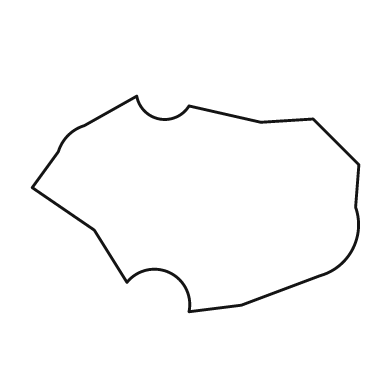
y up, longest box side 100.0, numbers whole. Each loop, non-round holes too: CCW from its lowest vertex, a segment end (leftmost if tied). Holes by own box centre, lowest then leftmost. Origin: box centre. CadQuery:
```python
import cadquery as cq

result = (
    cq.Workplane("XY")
    .moveTo(-2.0, -33.0)
    .lineTo(14.0, -31.0)
    .lineTo(38.0, -22.0)
    .threePointArc((48.0, -14.0), (49.0, -1.0))
    .lineTo(50.0, 12.0)
    .lineTo(36.0, 26.0)
    .lineTo(20.0, 25.0)
    .lineTo(-2.0, 30.0)
    .threePointArc((-11.0, 26.0), (-18.0, 33.0))
    .lineTo(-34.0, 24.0)
    .threePointArc((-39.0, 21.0), (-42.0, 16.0))
    .lineTo(-50.0, 5.0)
    .lineTo(-31.0, -8.0)
    .lineTo(-21.0, -24.0)
    .threePointArc((-8.0, -21.0), (-2.0, -33.0))
    .close()
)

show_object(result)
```